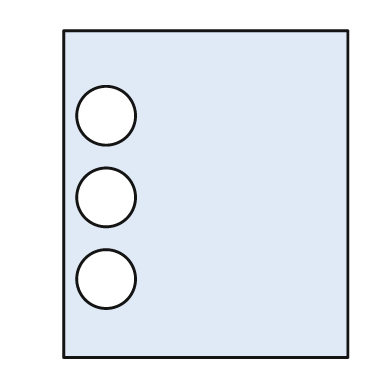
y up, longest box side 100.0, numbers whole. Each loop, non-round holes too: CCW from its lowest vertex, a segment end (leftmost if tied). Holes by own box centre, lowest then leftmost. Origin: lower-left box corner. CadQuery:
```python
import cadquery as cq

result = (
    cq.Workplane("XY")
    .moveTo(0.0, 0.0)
    .lineTo(87.0, 0.0)
    .lineTo(87.0, 100.0)
    .lineTo(0.0, 100.0)
    .close()
    .moveTo(13.0, 24.0)
    .circle(9.0)
    .moveTo(13.0, 49.0)
    .circle(9.0)
    .moveTo(13.0, 74.0)
    .circle(9.0)
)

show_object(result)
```